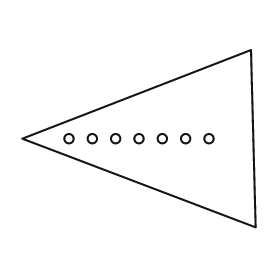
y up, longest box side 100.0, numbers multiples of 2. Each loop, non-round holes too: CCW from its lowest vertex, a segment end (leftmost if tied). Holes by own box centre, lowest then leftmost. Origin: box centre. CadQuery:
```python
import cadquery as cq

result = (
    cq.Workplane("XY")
    .moveTo(50.0, -38.0)
    .lineTo(48.0, 38.0)
    .lineTo(-50.0, 0.0)
    .close()
    .moveTo(-30.0, 0.0)
    .circle(2.0)
    .moveTo(-20.0, 0.0)
    .circle(2.0)
    .moveTo(-10.0, 0.0)
    .circle(2.0)
    .moveTo(0.0, 0.0)
    .circle(2.0)
    .moveTo(10.0, 0.0)
    .circle(2.0)
    .moveTo(20.0, 0.0)
    .circle(2.0)
    .moveTo(30.0, 0.0)
    .circle(2.0)
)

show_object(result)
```